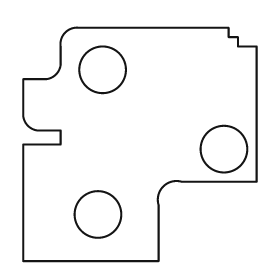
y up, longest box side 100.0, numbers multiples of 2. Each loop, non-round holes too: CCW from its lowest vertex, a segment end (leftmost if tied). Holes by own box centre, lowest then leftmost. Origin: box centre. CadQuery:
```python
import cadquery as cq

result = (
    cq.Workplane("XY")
    .moveTo(-50.0, -50.0)
    .lineTo(8.0, -50.0)
    .lineTo(8.0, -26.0)
    .threePointArc((10.0, -18.0), (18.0, -16.0))
    .lineTo(50.0, -16.0)
    .lineTo(50.0, 42.0)
    .lineTo(42.0, 42.0)
    .lineTo(42.0, 46.0)
    .lineTo(38.0, 46.0)
    .lineTo(38.0, 50.0)
    .lineTo(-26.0, 50.0)
    .threePointArc((-32.0, 48.0), (-34.0, 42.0))
    .lineTo(-34.0, 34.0)
    .threePointArc((-36.0, 30.0), (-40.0, 28.0))
    .lineTo(-50.0, 28.0)
    .lineTo(-50.0, 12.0)
    .threePointArc((-48.0, 8.0), (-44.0, 6.0))
    .lineTo(-34.0, 6.0)
    .lineTo(-34.0, 0.0)
    .lineTo(-50.0, 0.0)
    .close()
    .moveTo(-18.0, -30.0)
    .circle(10.0)
    .moveTo(36.0, -2.0)
    .circle(10.0)
    .moveTo(-16.0, 32.0)
    .circle(10.0)
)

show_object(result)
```